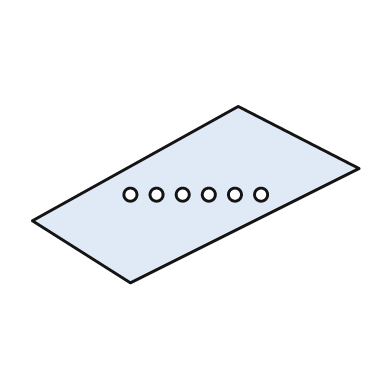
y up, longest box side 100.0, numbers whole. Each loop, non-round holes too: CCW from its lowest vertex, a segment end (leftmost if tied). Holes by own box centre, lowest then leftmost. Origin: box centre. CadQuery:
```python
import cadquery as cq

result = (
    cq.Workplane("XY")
    .moveTo(-20.0, -27.0)
    .lineTo(50.0, 8.0)
    .lineTo(13.0, 27.0)
    .lineTo(-50.0, -8.0)
    .close()
    .moveTo(-20.0, 0.0)
    .circle(2.0)
    .moveTo(-12.0, 0.0)
    .circle(2.0)
    .moveTo(-4.0, 0.0)
    .circle(2.0)
    .moveTo(4.0, 0.0)
    .circle(2.0)
    .moveTo(12.0, 0.0)
    .circle(2.0)
    .moveTo(20.0, 0.0)
    .circle(2.0)
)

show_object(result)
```